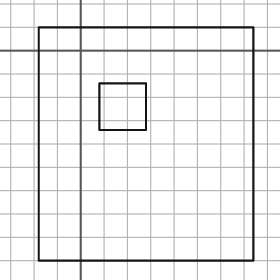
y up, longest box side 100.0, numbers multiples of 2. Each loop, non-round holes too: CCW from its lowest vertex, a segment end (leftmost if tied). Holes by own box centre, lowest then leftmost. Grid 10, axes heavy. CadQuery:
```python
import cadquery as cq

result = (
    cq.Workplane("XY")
    .moveTo(-18.0, -90.0)
    .lineTo(74.0, -90.0)
    .lineTo(74.0, 10.0)
    .lineTo(-18.0, 10.0)
    .close()
    .moveTo(8.0, -34.0)
    .lineTo(28.0, -34.0)
    .lineTo(28.0, -14.0)
    .lineTo(8.0, -14.0)
    .close()
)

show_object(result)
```